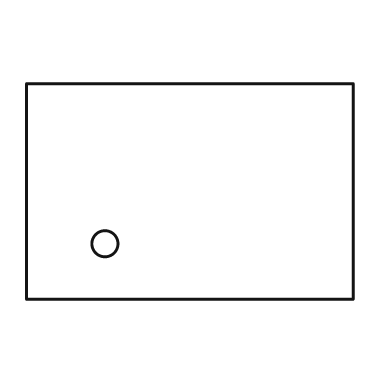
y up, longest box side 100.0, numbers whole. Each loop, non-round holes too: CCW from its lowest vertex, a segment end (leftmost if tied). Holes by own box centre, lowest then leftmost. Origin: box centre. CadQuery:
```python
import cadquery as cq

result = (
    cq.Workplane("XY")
    .moveTo(-50.0, -33.0)
    .lineTo(50.0, -33.0)
    .lineTo(50.0, 33.0)
    .lineTo(-50.0, 33.0)
    .close()
    .moveTo(-26.0, -16.0)
    .circle(4.0)
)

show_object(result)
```